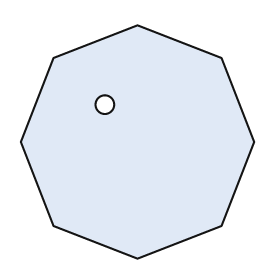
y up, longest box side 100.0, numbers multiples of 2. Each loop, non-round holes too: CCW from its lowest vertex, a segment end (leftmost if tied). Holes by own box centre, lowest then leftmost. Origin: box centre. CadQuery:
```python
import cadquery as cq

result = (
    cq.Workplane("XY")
    .moveTo(0.0, -50.0)
    .lineTo(36.0, -36.0)
    .lineTo(50.0, 0.0)
    .lineTo(36.0, 36.0)
    .lineTo(0.0, 50.0)
    .lineTo(-36.0, 36.0)
    .lineTo(-50.0, 0.0)
    .lineTo(-36.0, -36.0)
    .close()
    .moveTo(-14.0, 16.0)
    .circle(4.0)
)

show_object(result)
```